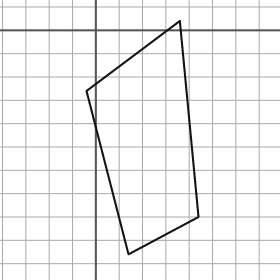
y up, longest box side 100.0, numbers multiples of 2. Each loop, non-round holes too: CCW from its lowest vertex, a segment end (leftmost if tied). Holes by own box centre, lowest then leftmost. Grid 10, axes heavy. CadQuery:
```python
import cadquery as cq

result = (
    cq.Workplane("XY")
    .moveTo(14.0, -96.0)
    .lineTo(44.0, -80.0)
    .lineTo(36.0, 4.0)
    .lineTo(-4.0, -26.0)
    .close()
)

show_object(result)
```